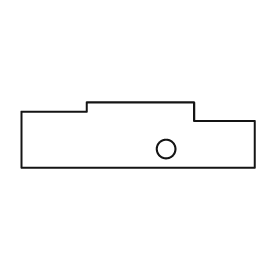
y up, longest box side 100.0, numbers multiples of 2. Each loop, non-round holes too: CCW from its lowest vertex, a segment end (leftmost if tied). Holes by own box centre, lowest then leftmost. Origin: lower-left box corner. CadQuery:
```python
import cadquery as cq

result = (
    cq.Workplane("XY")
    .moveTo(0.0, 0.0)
    .lineTo(100.0, 0.0)
    .lineTo(100.0, 20.0)
    .lineTo(74.0, 20.0)
    .lineTo(74.0, 28.0)
    .lineTo(28.0, 28.0)
    .lineTo(28.0, 24.0)
    .lineTo(0.0, 24.0)
    .close()
    .moveTo(62.0, 8.0)
    .circle(4.0)
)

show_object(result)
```